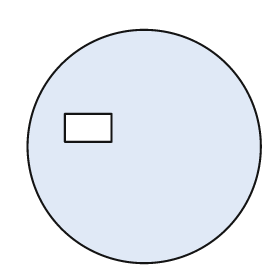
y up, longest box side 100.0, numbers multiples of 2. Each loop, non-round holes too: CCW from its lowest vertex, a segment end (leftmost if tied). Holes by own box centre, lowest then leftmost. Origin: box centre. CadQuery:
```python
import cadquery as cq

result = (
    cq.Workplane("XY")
    .moveTo(0.0, 0.0)
    .circle(50.0)
    .moveTo(-34.0, 2.0)
    .lineTo(-14.0, 2.0)
    .lineTo(-14.0, 14.0)
    .lineTo(-34.0, 14.0)
    .close()
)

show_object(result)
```